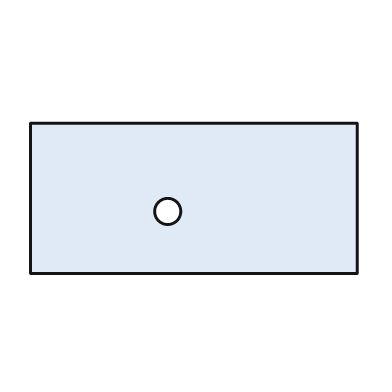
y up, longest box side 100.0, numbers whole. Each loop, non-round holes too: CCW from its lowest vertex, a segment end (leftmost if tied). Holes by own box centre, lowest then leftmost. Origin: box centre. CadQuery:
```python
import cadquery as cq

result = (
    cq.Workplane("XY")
    .moveTo(-50.0, -23.0)
    .lineTo(50.0, -23.0)
    .lineTo(50.0, 23.0)
    .lineTo(-50.0, 23.0)
    .close()
    .moveTo(-8.0, -4.0)
    .circle(4.0)
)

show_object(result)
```